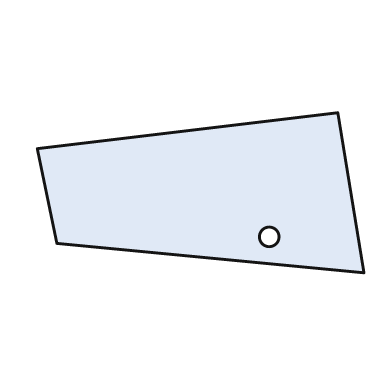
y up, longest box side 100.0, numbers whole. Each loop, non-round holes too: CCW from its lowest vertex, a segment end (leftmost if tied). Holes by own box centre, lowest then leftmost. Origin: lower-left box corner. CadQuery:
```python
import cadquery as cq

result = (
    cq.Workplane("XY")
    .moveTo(100.0, 0.0)
    .lineTo(92.0, 49.0)
    .lineTo(0.0, 38.0)
    .lineTo(6.0, 9.0)
    .close()
    .moveTo(71.0, 11.0)
    .circle(3.0)
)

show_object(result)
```